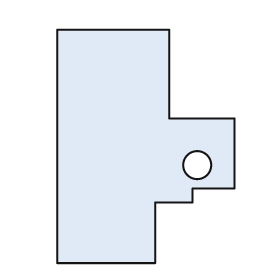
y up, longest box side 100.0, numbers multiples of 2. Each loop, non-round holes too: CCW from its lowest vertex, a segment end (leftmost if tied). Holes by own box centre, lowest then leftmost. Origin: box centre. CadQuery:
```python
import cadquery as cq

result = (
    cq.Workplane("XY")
    .moveTo(-38.0, -50.0)
    .lineTo(4.0, -50.0)
    .lineTo(4.0, -24.0)
    .lineTo(20.0, -24.0)
    .lineTo(20.0, -18.0)
    .lineTo(38.0, -18.0)
    .lineTo(38.0, 12.0)
    .lineTo(10.0, 12.0)
    .lineTo(10.0, 50.0)
    .lineTo(-38.0, 50.0)
    .close()
    .moveTo(22.0, -8.0)
    .circle(6.0)
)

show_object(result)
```